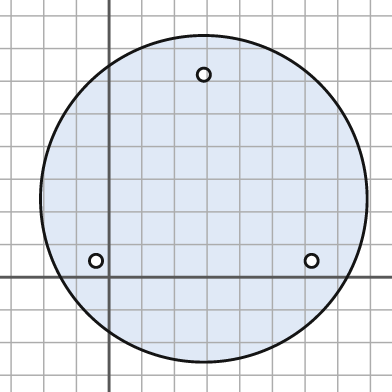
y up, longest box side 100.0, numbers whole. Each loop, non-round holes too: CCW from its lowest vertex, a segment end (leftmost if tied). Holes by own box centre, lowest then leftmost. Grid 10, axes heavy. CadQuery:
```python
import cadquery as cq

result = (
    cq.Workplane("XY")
    .moveTo(29.0, 24.0)
    .circle(50.0)
    .moveTo(-4.0, 5.0)
    .circle(2.0)
    .moveTo(62.0, 5.0)
    .circle(2.0)
    .moveTo(29.0, 62.0)
    .circle(2.0)
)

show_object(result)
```